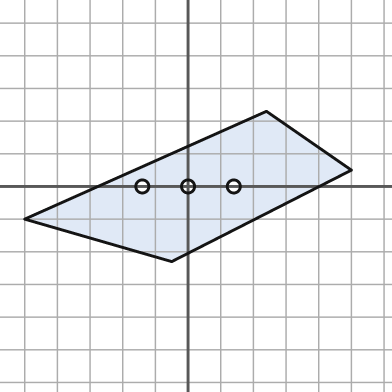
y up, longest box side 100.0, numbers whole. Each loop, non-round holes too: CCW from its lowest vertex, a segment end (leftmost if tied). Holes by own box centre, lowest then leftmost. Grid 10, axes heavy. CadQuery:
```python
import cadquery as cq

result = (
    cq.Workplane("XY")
    .moveTo(-5.0, -23.0)
    .lineTo(50.0, 5.0)
    .lineTo(24.0, 23.0)
    .lineTo(-50.0, -10.0)
    .close()
    .moveTo(-14.0, 0.0)
    .circle(2.0)
    .moveTo(0.0, 0.0)
    .circle(2.0)
    .moveTo(14.0, 0.0)
    .circle(2.0)
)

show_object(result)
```